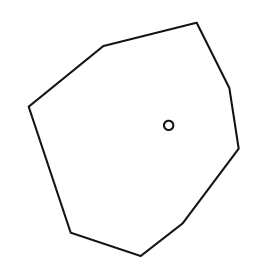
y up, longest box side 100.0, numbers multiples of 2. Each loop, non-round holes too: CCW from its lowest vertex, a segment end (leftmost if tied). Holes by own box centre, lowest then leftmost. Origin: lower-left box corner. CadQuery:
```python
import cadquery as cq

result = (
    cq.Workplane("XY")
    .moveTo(48.0, 0.0)
    .lineTo(66.0, 14.0)
    .lineTo(90.0, 46.0)
    .lineTo(86.0, 72.0)
    .lineTo(72.0, 100.0)
    .lineTo(32.0, 90.0)
    .lineTo(0.0, 64.0)
    .lineTo(18.0, 10.0)
    .close()
    .moveTo(60.0, 56.0)
    .circle(2.0)
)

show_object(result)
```